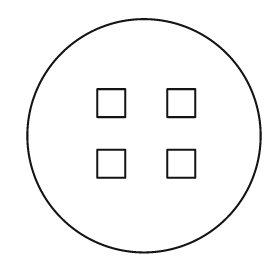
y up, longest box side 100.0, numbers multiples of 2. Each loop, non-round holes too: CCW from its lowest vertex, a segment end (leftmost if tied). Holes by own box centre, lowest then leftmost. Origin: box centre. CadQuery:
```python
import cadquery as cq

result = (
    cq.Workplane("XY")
    .moveTo(0.0, 0.0)
    .circle(50.0)
    .moveTo(-20.0, -18.0)
    .lineTo(-8.0, -18.0)
    .lineTo(-8.0, -6.0)
    .lineTo(-20.0, -6.0)
    .close()
    .moveTo(10.0, -18.0)
    .lineTo(22.0, -18.0)
    .lineTo(22.0, -6.0)
    .lineTo(10.0, -6.0)
    .close()
    .moveTo(-20.0, 8.0)
    .lineTo(-8.0, 8.0)
    .lineTo(-8.0, 20.0)
    .lineTo(-20.0, 20.0)
    .close()
    .moveTo(10.0, 8.0)
    .lineTo(22.0, 8.0)
    .lineTo(22.0, 20.0)
    .lineTo(10.0, 20.0)
    .close()
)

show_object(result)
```